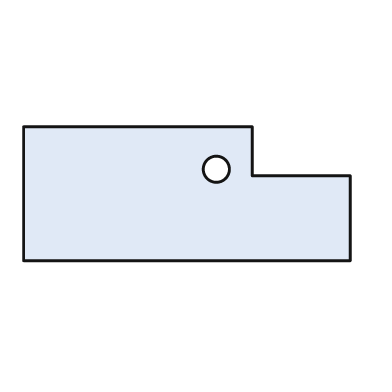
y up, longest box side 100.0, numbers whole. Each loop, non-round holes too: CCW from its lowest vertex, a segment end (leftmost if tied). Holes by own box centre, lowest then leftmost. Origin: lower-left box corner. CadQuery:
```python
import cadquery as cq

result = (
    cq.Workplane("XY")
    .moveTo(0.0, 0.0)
    .lineTo(100.0, 0.0)
    .lineTo(100.0, 26.0)
    .lineTo(70.0, 26.0)
    .lineTo(70.0, 41.0)
    .lineTo(0.0, 41.0)
    .close()
    .moveTo(59.0, 28.0)
    .circle(4.0)
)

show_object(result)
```